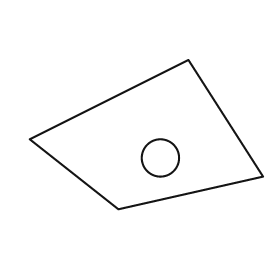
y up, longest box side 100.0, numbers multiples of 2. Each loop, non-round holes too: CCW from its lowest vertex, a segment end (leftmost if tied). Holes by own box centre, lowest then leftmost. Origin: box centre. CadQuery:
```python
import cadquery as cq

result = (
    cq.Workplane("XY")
    .moveTo(-12.0, -32.0)
    .lineTo(50.0, -18.0)
    .lineTo(18.0, 32.0)
    .lineTo(-50.0, -2.0)
    .close()
    .moveTo(6.0, -10.0)
    .circle(8.0)
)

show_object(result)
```